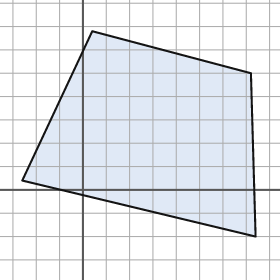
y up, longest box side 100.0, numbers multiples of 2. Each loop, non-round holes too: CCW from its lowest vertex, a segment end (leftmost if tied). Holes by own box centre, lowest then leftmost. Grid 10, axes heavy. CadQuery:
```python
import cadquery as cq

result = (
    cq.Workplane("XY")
    .moveTo(74.0, -20.0)
    .lineTo(72.0, 50.0)
    .lineTo(4.0, 68.0)
    .lineTo(-26.0, 4.0)
    .close()
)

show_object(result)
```